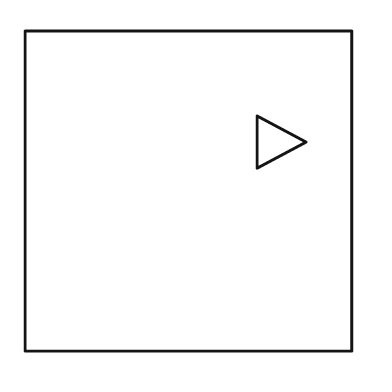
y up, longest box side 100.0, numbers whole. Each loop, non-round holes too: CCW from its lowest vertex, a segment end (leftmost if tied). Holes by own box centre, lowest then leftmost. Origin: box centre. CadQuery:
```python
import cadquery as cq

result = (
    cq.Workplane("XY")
    .moveTo(-50.0, -49.0)
    .lineTo(50.0, -49.0)
    .lineTo(50.0, 49.0)
    .lineTo(-50.0, 49.0)
    .close()
    .moveTo(21.0, 7.0)
    .lineTo(36.0, 15.0)
    .lineTo(21.0, 23.0)
    .close()
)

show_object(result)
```